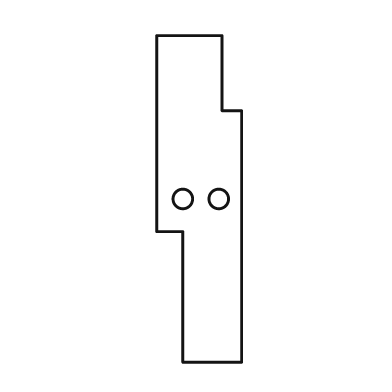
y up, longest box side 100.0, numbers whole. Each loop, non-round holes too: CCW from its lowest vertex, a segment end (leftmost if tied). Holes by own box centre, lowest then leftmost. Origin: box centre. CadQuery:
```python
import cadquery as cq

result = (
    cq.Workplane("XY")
    .moveTo(-5.0, -50.0)
    .lineTo(13.0, -50.0)
    .lineTo(13.0, 27.0)
    .lineTo(7.0, 27.0)
    .lineTo(7.0, 50.0)
    .lineTo(-13.0, 50.0)
    .lineTo(-13.0, -10.0)
    .lineTo(-5.0, -10.0)
    .close()
    .moveTo(-5.0, 0.0)
    .circle(3.0)
    .moveTo(6.0, 0.0)
    .circle(3.0)
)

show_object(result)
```